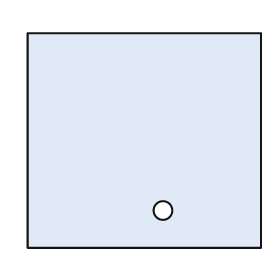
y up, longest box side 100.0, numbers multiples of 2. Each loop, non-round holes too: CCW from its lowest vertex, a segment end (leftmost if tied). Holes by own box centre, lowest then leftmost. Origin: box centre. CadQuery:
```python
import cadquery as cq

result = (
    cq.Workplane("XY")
    .moveTo(-50.0, -46.0)
    .lineTo(50.0, -46.0)
    .lineTo(50.0, 46.0)
    .lineTo(-50.0, 46.0)
    .close()
    .moveTo(8.0, -30.0)
    .circle(4.0)
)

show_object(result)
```